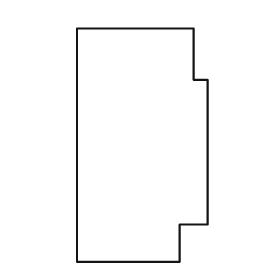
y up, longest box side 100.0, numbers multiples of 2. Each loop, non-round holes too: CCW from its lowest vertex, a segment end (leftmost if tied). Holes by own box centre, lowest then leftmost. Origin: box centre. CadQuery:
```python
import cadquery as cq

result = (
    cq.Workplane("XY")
    .moveTo(-28.0, -50.0)
    .lineTo(16.0, -50.0)
    .lineTo(16.0, -34.0)
    .lineTo(28.0, -34.0)
    .lineTo(28.0, 28.0)
    .lineTo(22.0, 28.0)
    .lineTo(22.0, 50.0)
    .lineTo(-28.0, 50.0)
    .close()
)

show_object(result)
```